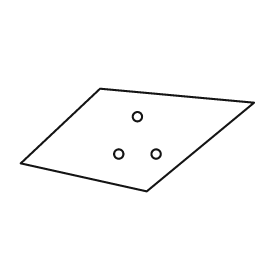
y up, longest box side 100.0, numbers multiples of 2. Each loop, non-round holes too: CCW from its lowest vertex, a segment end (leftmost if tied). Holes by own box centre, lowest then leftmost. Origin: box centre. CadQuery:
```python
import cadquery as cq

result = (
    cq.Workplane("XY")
    .moveTo(4.0, -22.0)
    .lineTo(50.0, 16.0)
    .lineTo(-16.0, 22.0)
    .lineTo(-50.0, -10.0)
    .close()
    .moveTo(-8.0, -6.0)
    .circle(2.0)
    .moveTo(8.0, -6.0)
    .circle(2.0)
    .moveTo(0.0, 10.0)
    .circle(2.0)
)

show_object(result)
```